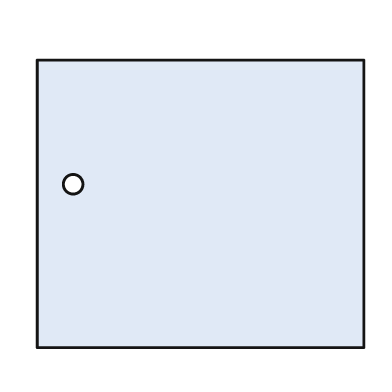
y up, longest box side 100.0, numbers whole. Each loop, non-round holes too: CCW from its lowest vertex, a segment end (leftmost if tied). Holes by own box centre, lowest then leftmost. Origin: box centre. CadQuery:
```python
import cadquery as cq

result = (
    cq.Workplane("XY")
    .moveTo(-50.0, -44.0)
    .lineTo(50.0, -44.0)
    .lineTo(50.0, 44.0)
    .lineTo(-50.0, 44.0)
    .close()
    .moveTo(-39.0, 6.0)
    .circle(3.0)
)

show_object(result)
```